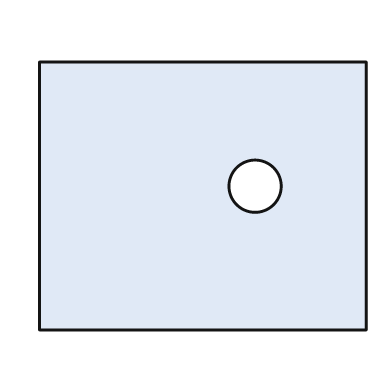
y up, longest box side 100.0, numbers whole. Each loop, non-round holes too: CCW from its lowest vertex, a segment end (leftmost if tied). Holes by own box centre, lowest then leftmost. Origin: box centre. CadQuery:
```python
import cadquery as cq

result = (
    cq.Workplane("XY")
    .moveTo(-50.0, -41.0)
    .lineTo(50.0, -41.0)
    .lineTo(50.0, 41.0)
    .lineTo(-50.0, 41.0)
    .close()
    .moveTo(16.0, 3.0)
    .circle(8.0)
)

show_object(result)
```